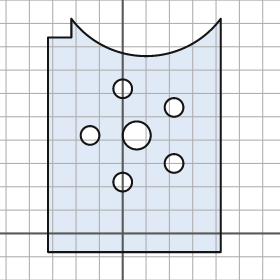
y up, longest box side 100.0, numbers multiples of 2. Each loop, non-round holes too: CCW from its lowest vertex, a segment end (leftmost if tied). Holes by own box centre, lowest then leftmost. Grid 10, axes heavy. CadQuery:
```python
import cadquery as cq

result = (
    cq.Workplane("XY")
    .moveTo(-32.0, -8.0)
    .lineTo(42.0, -8.0)
    .lineTo(42.0, 92.0)
    .threePointArc((10.0, 76.0), (-22.0, 92.0))
    .lineTo(-22.0, 84.0)
    .lineTo(-32.0, 84.0)
    .close()
    .moveTo(0.0, 22.0)
    .circle(4.0)
    .moveTo(22.0, 30.0)
    .circle(4.0)
    .moveTo(-14.0, 42.0)
    .circle(4.0)
    .moveTo(6.0, 42.0)
    .circle(6.0)
    .moveTo(22.0, 54.0)
    .circle(4.0)
    .moveTo(0.0, 62.0)
    .circle(4.0)
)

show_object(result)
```